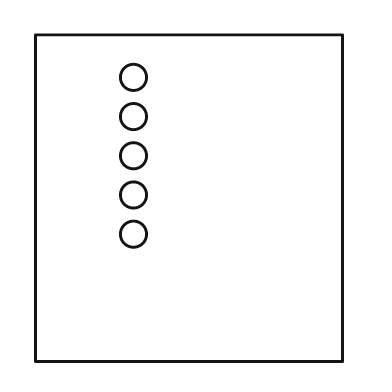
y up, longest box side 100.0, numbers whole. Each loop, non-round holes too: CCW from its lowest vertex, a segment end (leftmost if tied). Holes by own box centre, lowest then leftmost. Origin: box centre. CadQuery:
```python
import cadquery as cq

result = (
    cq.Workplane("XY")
    .moveTo(-47.0, -50.0)
    .lineTo(47.0, -50.0)
    .lineTo(47.0, 50.0)
    .lineTo(-47.0, 50.0)
    .close()
    .moveTo(-17.0, -11.0)
    .circle(4.0)
    .moveTo(-17.0, 1.0)
    .circle(4.0)
    .moveTo(-17.0, 13.0)
    .circle(4.0)
    .moveTo(-17.0, 25.0)
    .circle(4.0)
    .moveTo(-17.0, 37.0)
    .circle(4.0)
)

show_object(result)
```